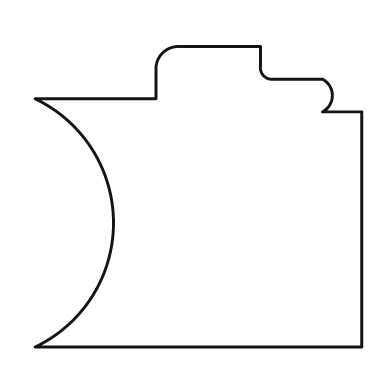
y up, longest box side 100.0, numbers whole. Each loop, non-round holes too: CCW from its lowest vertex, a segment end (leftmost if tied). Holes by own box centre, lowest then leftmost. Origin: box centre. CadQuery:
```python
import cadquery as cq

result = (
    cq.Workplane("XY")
    .moveTo(-50.0, -46.0)
    .lineTo(50.0, -46.0)
    .lineTo(50.0, 26.0)
    .lineTo(38.0, 26.0)
    .threePointArc((41.0, 31.0), (38.0, 36.0))
    .lineTo(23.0, 36.0)
    .threePointArc((20.0, 37.0), (19.0, 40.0))
    .lineTo(19.0, 46.0)
    .lineTo(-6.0, 46.0)
    .threePointArc((-11.0, 44.0), (-13.0, 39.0))
    .lineTo(-13.0, 30.0)
    .lineTo(-50.0, 30.0)
    .threePointArc((-26.0, -8.0), (-50.0, -46.0))
    .close()
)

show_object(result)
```